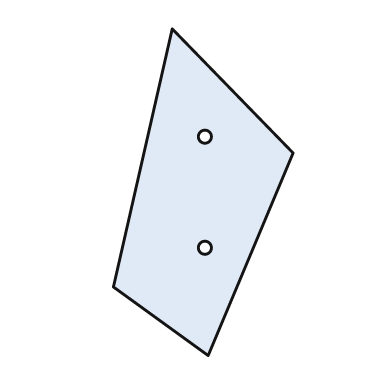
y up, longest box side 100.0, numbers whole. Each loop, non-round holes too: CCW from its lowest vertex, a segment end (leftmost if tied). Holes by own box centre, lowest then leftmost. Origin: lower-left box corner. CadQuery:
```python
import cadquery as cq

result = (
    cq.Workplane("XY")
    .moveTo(29.0, 0.0)
    .lineTo(55.0, 62.0)
    .lineTo(18.0, 100.0)
    .lineTo(0.0, 21.0)
    .close()
    .moveTo(28.0, 33.0)
    .circle(2.0)
    .moveTo(28.0, 67.0)
    .circle(2.0)
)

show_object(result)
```